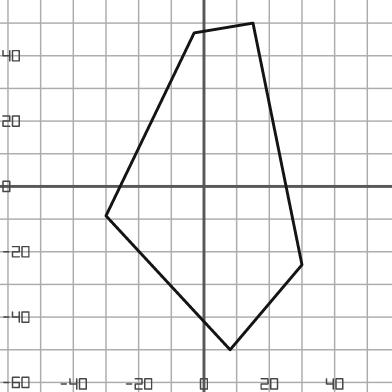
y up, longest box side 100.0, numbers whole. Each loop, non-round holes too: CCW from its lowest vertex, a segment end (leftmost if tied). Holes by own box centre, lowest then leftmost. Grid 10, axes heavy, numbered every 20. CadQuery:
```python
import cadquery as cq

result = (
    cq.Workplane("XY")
    .moveTo(8.0, -50.0)
    .lineTo(30.0, -24.0)
    .lineTo(15.0, 50.0)
    .lineTo(-3.0, 47.0)
    .lineTo(-30.0, -9.0)
    .close()
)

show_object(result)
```